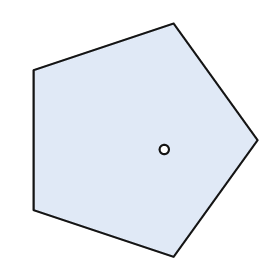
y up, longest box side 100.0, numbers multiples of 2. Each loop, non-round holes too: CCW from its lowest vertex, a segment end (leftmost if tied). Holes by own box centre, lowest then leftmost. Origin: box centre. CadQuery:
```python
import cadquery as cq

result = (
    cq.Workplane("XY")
    .moveTo(12.0, -50.0)
    .lineTo(48.0, 0.0)
    .lineTo(12.0, 50.0)
    .lineTo(-48.0, 30.0)
    .lineTo(-48.0, -30.0)
    .close()
    .moveTo(8.0, -4.0)
    .circle(2.0)
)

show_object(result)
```